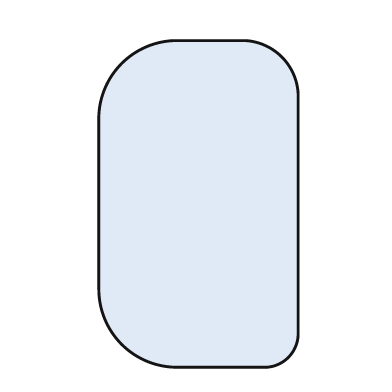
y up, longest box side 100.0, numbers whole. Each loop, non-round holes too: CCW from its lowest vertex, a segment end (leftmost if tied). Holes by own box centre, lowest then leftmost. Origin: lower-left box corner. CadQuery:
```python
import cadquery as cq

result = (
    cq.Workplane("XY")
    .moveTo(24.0, 0.0)
    .lineTo(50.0, 0.0)
    .threePointArc((58.0, 3.0), (61.0, 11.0))
    .lineTo(61.0, 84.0)
    .threePointArc((56.0, 95.0), (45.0, 100.0))
    .lineTo(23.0, 100.0)
    .threePointArc((7.0, 93.0), (0.0, 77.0))
    .lineTo(0.0, 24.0)
    .threePointArc((7.0, 7.0), (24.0, 0.0))
    .close()
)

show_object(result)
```